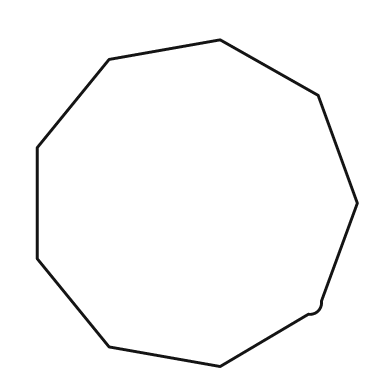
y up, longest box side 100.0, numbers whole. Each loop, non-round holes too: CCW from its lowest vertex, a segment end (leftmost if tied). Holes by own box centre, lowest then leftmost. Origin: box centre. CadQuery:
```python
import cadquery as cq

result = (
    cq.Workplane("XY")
    .moveTo(7.0, -50.0)
    .lineTo(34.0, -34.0)
    .threePointArc((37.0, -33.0), (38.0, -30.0))
    .lineTo(49.0, 0.0)
    .lineTo(37.0, 33.0)
    .lineTo(7.0, 50.0)
    .lineTo(-27.0, 44.0)
    .lineTo(-49.0, 17.0)
    .lineTo(-49.0, -17.0)
    .lineTo(-27.0, -44.0)
    .close()
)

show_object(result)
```